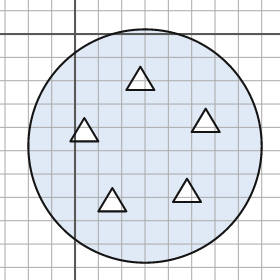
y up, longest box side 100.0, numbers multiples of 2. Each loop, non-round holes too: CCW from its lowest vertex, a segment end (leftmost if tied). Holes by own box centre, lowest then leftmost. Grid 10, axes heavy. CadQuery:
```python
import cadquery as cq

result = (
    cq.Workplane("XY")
    .moveTo(30.0, -48.0)
    .circle(50.0)
    .moveTo(10.0, -76.0)
    .lineTo(22.0, -76.0)
    .lineTo(16.0, -66.0)
    .close()
    .moveTo(42.0, -72.0)
    .lineTo(54.0, -72.0)
    .lineTo(48.0, -62.0)
    .close()
    .moveTo(-2.0, -46.0)
    .lineTo(10.0, -46.0)
    .lineTo(4.0, -36.0)
    .close()
    .moveTo(50.0, -42.0)
    .lineTo(62.0, -42.0)
    .lineTo(56.0, -32.0)
    .close()
    .moveTo(22.0, -24.0)
    .lineTo(34.0, -24.0)
    .lineTo(28.0, -14.0)
    .close()
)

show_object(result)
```